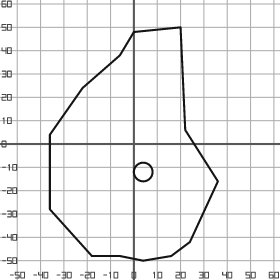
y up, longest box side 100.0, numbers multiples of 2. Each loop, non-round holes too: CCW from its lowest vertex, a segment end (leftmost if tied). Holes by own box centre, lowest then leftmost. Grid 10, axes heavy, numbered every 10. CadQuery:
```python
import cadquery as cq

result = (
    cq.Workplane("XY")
    .moveTo(4.0, -50.0)
    .lineTo(16.0, -48.0)
    .lineTo(24.0, -42.0)
    .lineTo(36.0, -16.0)
    .lineTo(22.0, 6.0)
    .lineTo(20.0, 50.0)
    .lineTo(0.0, 48.0)
    .lineTo(-6.0, 38.0)
    .lineTo(-22.0, 24.0)
    .lineTo(-36.0, 4.0)
    .lineTo(-36.0, -28.0)
    .lineTo(-18.0, -48.0)
    .lineTo(-6.0, -48.0)
    .close()
    .moveTo(4.0, -12.0)
    .circle(4.0)
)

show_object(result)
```